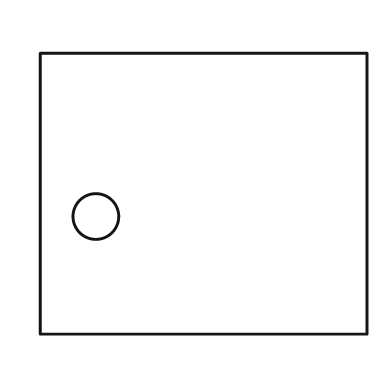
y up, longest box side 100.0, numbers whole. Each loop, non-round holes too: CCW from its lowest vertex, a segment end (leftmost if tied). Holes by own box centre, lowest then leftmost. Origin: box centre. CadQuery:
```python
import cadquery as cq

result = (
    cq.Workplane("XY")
    .moveTo(-50.0, -43.0)
    .lineTo(50.0, -43.0)
    .lineTo(50.0, 43.0)
    .lineTo(-50.0, 43.0)
    .close()
    .moveTo(-33.0, -7.0)
    .circle(7.0)
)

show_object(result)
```